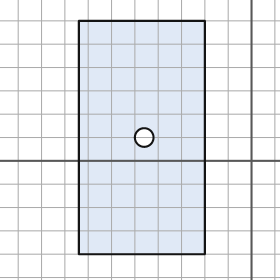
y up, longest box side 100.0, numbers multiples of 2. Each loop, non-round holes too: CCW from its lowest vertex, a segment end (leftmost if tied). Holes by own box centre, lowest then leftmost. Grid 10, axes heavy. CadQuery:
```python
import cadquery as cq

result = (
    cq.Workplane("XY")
    .moveTo(-74.0, -40.0)
    .lineTo(-20.0, -40.0)
    .lineTo(-20.0, 60.0)
    .lineTo(-74.0, 60.0)
    .close()
    .moveTo(-46.0, 10.0)
    .circle(4.0)
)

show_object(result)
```